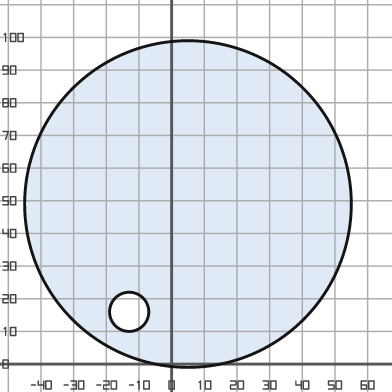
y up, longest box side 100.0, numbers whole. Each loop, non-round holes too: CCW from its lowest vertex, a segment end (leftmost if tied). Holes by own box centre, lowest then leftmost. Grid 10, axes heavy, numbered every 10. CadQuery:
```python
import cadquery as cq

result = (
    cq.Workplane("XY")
    .moveTo(5.0, 49.0)
    .circle(50.0)
    .moveTo(-13.0, 16.0)
    .circle(6.0)
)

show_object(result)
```